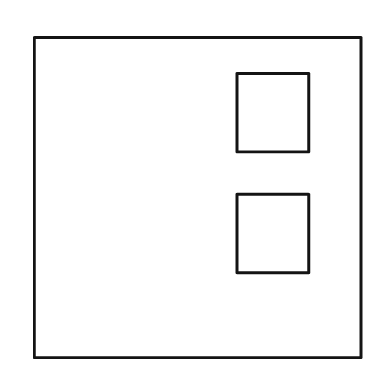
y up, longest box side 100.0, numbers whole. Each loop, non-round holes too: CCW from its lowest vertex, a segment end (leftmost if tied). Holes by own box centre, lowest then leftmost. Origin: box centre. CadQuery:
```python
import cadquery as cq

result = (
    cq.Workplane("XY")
    .moveTo(-50.0, -49.0)
    .lineTo(50.0, -49.0)
    .lineTo(50.0, 49.0)
    .lineTo(-50.0, 49.0)
    .close()
    .moveTo(12.0, -23.0)
    .lineTo(34.0, -23.0)
    .lineTo(34.0, 1.0)
    .lineTo(12.0, 1.0)
    .close()
    .moveTo(12.0, 14.0)
    .lineTo(34.0, 14.0)
    .lineTo(34.0, 38.0)
    .lineTo(12.0, 38.0)
    .close()
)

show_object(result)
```